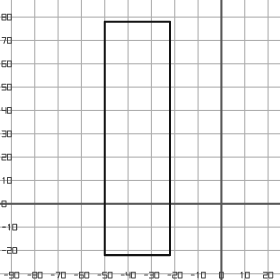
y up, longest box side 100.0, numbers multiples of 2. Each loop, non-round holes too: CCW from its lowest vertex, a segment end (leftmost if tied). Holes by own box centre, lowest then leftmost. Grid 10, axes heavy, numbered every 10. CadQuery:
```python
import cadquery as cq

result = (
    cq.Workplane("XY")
    .moveTo(-50.0, -22.0)
    .lineTo(-22.0, -22.0)
    .lineTo(-22.0, 78.0)
    .lineTo(-50.0, 78.0)
    .close()
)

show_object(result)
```